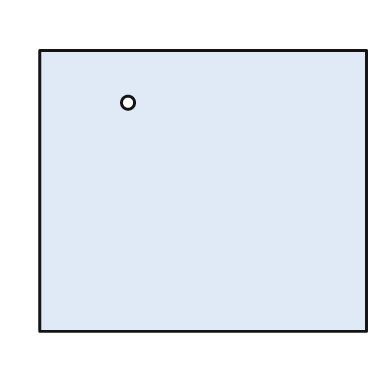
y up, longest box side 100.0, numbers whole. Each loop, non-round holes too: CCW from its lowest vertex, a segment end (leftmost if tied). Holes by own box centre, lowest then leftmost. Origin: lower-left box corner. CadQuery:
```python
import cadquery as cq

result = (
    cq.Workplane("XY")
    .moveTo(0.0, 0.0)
    .lineTo(100.0, 0.0)
    .lineTo(100.0, 86.0)
    .lineTo(0.0, 86.0)
    .close()
    .moveTo(27.0, 70.0)
    .circle(2.0)
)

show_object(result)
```